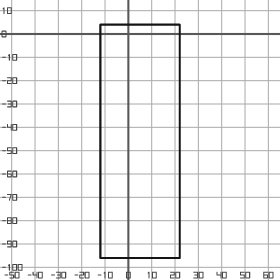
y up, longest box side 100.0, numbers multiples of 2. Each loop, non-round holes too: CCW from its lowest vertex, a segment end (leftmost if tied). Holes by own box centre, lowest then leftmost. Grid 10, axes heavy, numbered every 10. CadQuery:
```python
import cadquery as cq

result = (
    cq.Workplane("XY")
    .moveTo(-12.0, -96.0)
    .lineTo(22.0, -96.0)
    .lineTo(22.0, 4.0)
    .lineTo(-12.0, 4.0)
    .close()
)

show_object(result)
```